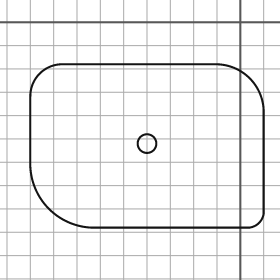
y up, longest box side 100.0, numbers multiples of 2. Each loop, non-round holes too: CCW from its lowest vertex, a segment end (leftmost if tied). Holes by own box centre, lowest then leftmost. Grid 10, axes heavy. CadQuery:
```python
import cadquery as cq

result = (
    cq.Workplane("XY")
    .moveTo(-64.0, -88.0)
    .lineTo(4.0, -88.0)
    .threePointArc((8.0, -86.0), (10.0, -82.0))
    .lineTo(10.0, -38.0)
    .threePointArc((4.0, -24.0), (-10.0, -18.0))
    .lineTo(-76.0, -18.0)
    .threePointArc((-86.0, -22.0), (-90.0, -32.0))
    .lineTo(-90.0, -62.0)
    .threePointArc((-82.0, -80.0), (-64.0, -88.0))
    .close()
    .moveTo(-40.0, -52.0)
    .circle(4.0)
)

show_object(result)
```